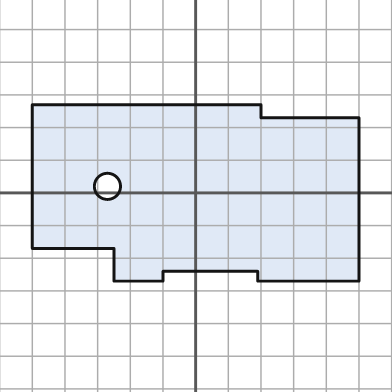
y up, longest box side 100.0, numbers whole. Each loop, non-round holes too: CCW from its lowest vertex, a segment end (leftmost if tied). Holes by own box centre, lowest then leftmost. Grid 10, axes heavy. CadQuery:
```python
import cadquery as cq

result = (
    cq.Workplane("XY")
    .moveTo(-25.0, -27.0)
    .lineTo(-10.0, -27.0)
    .lineTo(-10.0, -24.0)
    .lineTo(19.0, -24.0)
    .lineTo(19.0, -27.0)
    .lineTo(50.0, -27.0)
    .lineTo(50.0, 23.0)
    .lineTo(20.0, 23.0)
    .lineTo(20.0, 27.0)
    .lineTo(-50.0, 27.0)
    .lineTo(-50.0, -17.0)
    .lineTo(-25.0, -17.0)
    .close()
    .moveTo(-27.0, 2.0)
    .circle(4.0)
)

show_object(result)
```